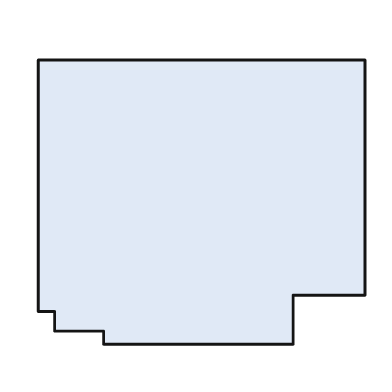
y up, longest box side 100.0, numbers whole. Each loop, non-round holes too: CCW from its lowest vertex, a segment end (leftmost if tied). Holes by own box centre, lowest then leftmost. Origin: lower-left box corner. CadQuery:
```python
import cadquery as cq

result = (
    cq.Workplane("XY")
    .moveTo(20.0, 0.0)
    .lineTo(78.0, 0.0)
    .lineTo(78.0, 15.0)
    .lineTo(100.0, 15.0)
    .lineTo(100.0, 87.0)
    .lineTo(0.0, 87.0)
    .lineTo(0.0, 10.0)
    .lineTo(5.0, 10.0)
    .lineTo(5.0, 4.0)
    .lineTo(20.0, 4.0)
    .close()
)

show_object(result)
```